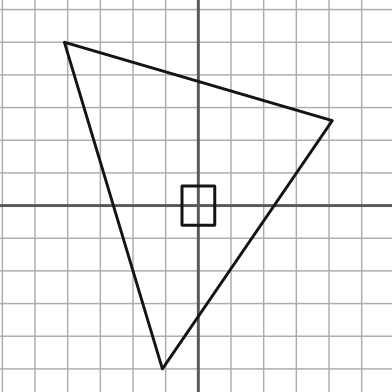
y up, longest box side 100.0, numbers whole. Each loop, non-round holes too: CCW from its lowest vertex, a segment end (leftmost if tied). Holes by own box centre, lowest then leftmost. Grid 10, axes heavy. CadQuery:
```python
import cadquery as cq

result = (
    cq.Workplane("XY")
    .moveTo(-11.0, -50.0)
    .lineTo(41.0, 26.0)
    .lineTo(-41.0, 50.0)
    .close()
    .moveTo(-5.0, -6.0)
    .lineTo(5.0, -6.0)
    .lineTo(5.0, 6.0)
    .lineTo(-5.0, 6.0)
    .close()
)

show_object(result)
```